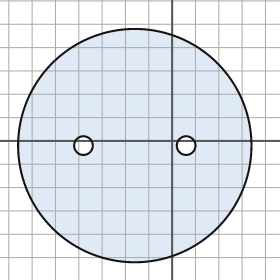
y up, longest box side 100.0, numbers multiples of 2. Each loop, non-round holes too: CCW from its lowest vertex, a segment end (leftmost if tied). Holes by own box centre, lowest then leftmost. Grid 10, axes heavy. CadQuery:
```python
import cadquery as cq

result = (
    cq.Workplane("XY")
    .moveTo(-16.0, -2.0)
    .circle(50.0)
    .moveTo(-38.0, -2.0)
    .circle(4.0)
    .moveTo(6.0, -2.0)
    .circle(4.0)
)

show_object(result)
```